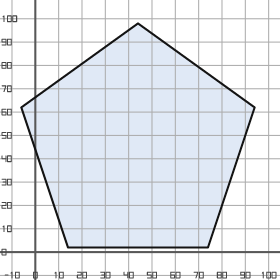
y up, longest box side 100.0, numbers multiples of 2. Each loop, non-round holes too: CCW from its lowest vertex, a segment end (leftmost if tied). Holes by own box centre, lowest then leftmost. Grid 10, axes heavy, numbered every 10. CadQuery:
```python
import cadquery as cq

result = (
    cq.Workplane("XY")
    .moveTo(14.0, 2.0)
    .lineTo(74.0, 2.0)
    .lineTo(94.0, 62.0)
    .lineTo(44.0, 98.0)
    .lineTo(-6.0, 62.0)
    .close()
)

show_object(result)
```